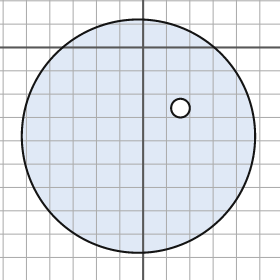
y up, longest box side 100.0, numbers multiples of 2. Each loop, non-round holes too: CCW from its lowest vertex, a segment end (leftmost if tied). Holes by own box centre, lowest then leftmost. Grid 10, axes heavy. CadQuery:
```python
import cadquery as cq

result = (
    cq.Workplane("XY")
    .moveTo(-2.0, -38.0)
    .circle(50.0)
    .moveTo(16.0, -26.0)
    .circle(4.0)
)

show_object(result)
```